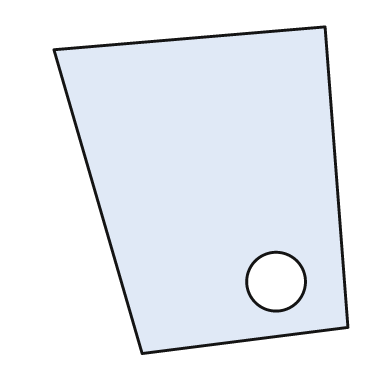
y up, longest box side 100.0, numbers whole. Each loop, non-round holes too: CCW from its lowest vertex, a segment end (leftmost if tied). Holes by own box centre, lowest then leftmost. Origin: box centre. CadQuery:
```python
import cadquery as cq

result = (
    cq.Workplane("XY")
    .moveTo(-18.0, -50.0)
    .lineTo(45.0, -42.0)
    .lineTo(38.0, 50.0)
    .lineTo(-45.0, 43.0)
    .close()
    .moveTo(23.0, -28.0)
    .circle(9.0)
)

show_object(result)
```